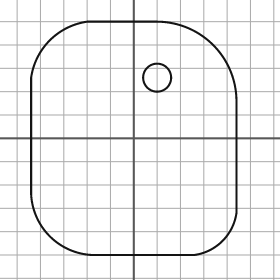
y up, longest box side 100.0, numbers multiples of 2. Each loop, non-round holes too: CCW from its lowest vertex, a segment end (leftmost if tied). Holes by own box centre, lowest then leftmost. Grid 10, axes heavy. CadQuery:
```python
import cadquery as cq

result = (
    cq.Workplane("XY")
    .moveTo(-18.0, -50.0)
    .lineTo(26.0, -50.0)
    .threePointArc((38.0, -44.0), (44.0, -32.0))
    .lineTo(44.0, 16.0)
    .threePointArc((34.0, 40.0), (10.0, 50.0))
    .lineTo(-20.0, 50.0)
    .threePointArc((-36.0, 42.0), (-44.0, 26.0))
    .lineTo(-44.0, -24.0)
    .threePointArc((-36.0, -42.0), (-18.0, -50.0))
    .close()
    .moveTo(10.0, 26.0)
    .circle(6.0)
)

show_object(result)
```